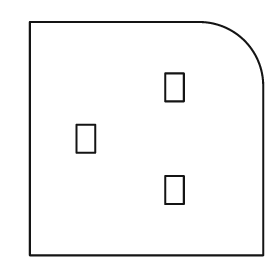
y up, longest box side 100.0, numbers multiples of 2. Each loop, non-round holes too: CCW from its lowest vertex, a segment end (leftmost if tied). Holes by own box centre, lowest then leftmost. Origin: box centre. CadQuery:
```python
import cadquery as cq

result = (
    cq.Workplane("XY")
    .moveTo(-50.0, -50.0)
    .lineTo(50.0, -50.0)
    .lineTo(50.0, 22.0)
    .threePointArc((42.0, 42.0), (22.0, 50.0))
    .lineTo(-50.0, 50.0)
    .close()
    .moveTo(8.0, -28.0)
    .lineTo(16.0, -28.0)
    .lineTo(16.0, -16.0)
    .lineTo(8.0, -16.0)
    .close()
    .moveTo(-30.0, -6.0)
    .lineTo(-22.0, -6.0)
    .lineTo(-22.0, 6.0)
    .lineTo(-30.0, 6.0)
    .close()
    .moveTo(8.0, 16.0)
    .lineTo(16.0, 16.0)
    .lineTo(16.0, 28.0)
    .lineTo(8.0, 28.0)
    .close()
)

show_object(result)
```